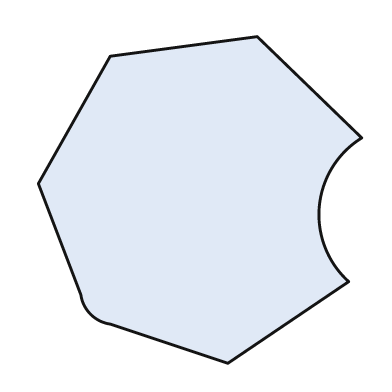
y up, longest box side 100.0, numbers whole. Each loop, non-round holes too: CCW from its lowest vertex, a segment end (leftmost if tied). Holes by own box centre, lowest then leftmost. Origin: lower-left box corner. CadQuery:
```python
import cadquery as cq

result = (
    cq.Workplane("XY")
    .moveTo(58.0, 0.0)
    .lineTo(95.0, 25.0)
    .threePointArc((86.0, 48.0), (99.0, 69.0))
    .lineTo(67.0, 100.0)
    .lineTo(22.0, 94.0)
    .lineTo(0.0, 55.0)
    .lineTo(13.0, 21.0)
    .threePointArc((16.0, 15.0), (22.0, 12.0))
    .close()
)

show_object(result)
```